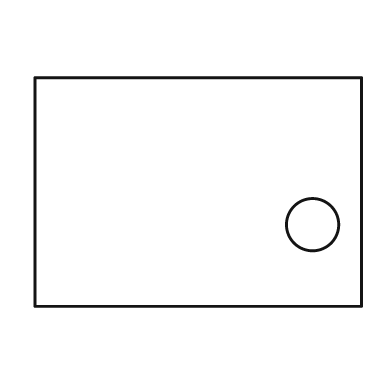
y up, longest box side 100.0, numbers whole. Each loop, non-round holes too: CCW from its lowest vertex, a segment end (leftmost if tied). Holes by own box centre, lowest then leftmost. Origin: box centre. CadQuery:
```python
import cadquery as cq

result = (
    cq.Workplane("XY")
    .moveTo(-50.0, -35.0)
    .lineTo(50.0, -35.0)
    .lineTo(50.0, 35.0)
    .lineTo(-50.0, 35.0)
    .close()
    .moveTo(35.0, -10.0)
    .circle(8.0)
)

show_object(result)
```